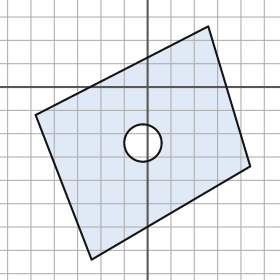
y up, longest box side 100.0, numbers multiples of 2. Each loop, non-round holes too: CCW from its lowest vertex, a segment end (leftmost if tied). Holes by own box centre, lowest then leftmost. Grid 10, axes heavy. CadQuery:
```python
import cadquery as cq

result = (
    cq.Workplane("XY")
    .moveTo(-24.0, -74.0)
    .lineTo(44.0, -34.0)
    .lineTo(26.0, 26.0)
    .lineTo(-48.0, -12.0)
    .close()
    .moveTo(-2.0, -24.0)
    .circle(8.0)
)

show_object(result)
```